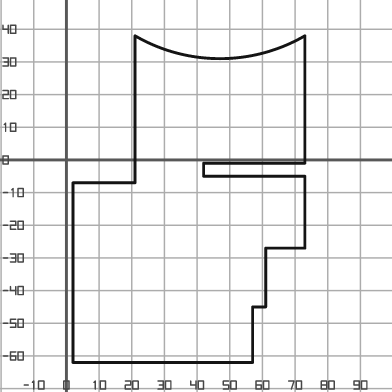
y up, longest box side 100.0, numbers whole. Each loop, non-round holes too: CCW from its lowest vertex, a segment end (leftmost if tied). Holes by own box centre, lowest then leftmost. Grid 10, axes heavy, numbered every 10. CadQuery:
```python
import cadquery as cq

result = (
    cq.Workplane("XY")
    .moveTo(2.0, -62.0)
    .lineTo(57.0, -62.0)
    .lineTo(57.0, -45.0)
    .lineTo(61.0, -45.0)
    .lineTo(61.0, -27.0)
    .lineTo(73.0, -27.0)
    .lineTo(73.0, -5.0)
    .lineTo(42.0, -5.0)
    .lineTo(42.0, -1.0)
    .lineTo(73.0, -1.0)
    .lineTo(73.0, 38.0)
    .threePointArc((47.0, 31.0), (21.0, 38.0))
    .lineTo(21.0, -7.0)
    .lineTo(2.0, -7.0)
    .close()
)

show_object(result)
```